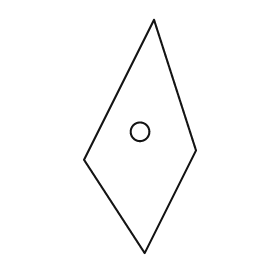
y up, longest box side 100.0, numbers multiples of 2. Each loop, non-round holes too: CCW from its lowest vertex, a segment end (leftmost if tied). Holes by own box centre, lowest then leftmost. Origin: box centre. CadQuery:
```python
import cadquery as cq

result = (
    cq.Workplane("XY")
    .moveTo(2.0, -50.0)
    .lineTo(24.0, -6.0)
    .lineTo(6.0, 50.0)
    .lineTo(-24.0, -10.0)
    .close()
    .moveTo(0.0, 2.0)
    .circle(4.0)
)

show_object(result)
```